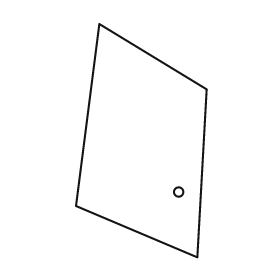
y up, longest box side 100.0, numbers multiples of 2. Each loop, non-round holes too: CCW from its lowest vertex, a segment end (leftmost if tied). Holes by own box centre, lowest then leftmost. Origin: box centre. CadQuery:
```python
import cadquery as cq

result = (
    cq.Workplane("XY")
    .moveTo(24.0, -50.0)
    .lineTo(28.0, 22.0)
    .lineTo(-18.0, 50.0)
    .lineTo(-28.0, -28.0)
    .close()
    .moveTo(16.0, -22.0)
    .circle(2.0)
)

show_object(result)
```